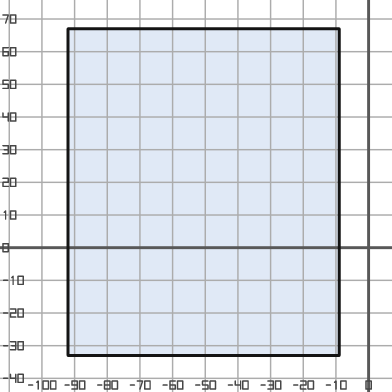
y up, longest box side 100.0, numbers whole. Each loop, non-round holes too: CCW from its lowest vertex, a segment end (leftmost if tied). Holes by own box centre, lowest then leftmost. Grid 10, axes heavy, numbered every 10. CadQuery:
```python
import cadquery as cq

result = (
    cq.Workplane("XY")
    .moveTo(-92.0, -33.0)
    .lineTo(-9.0, -33.0)
    .lineTo(-9.0, 67.0)
    .lineTo(-92.0, 67.0)
    .close()
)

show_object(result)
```